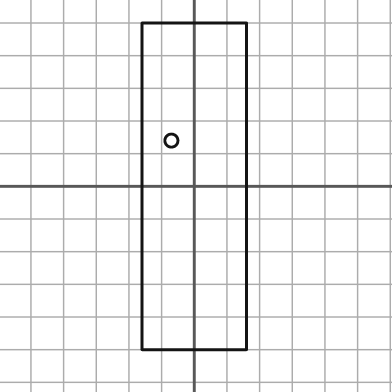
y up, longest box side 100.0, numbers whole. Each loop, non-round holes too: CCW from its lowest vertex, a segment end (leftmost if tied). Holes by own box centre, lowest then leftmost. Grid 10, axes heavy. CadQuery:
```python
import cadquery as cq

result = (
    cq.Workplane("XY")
    .moveTo(-16.0, -50.0)
    .lineTo(16.0, -50.0)
    .lineTo(16.0, 50.0)
    .lineTo(-16.0, 50.0)
    .close()
    .moveTo(-7.0, 14.0)
    .circle(2.0)
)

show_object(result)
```